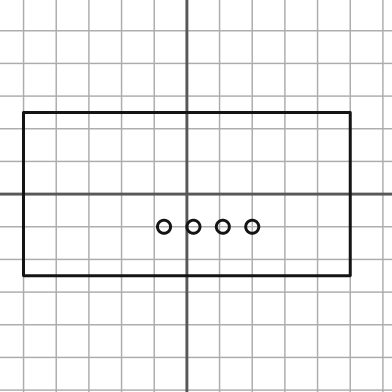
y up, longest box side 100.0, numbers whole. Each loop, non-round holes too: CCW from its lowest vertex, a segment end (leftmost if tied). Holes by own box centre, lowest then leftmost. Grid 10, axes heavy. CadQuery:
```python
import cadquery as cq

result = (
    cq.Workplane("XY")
    .moveTo(-50.0, -25.0)
    .lineTo(50.0, -25.0)
    .lineTo(50.0, 25.0)
    .lineTo(-50.0, 25.0)
    .close()
    .moveTo(-7.0, -10.0)
    .circle(2.0)
    .moveTo(2.0, -10.0)
    .circle(2.0)
    .moveTo(11.0, -10.0)
    .circle(2.0)
    .moveTo(20.0, -10.0)
    .circle(2.0)
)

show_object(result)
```